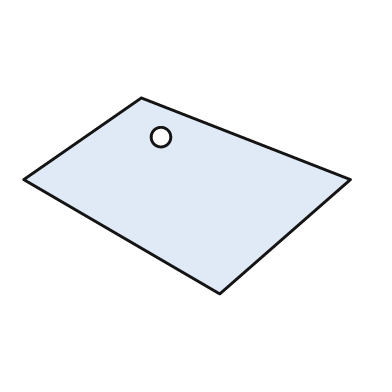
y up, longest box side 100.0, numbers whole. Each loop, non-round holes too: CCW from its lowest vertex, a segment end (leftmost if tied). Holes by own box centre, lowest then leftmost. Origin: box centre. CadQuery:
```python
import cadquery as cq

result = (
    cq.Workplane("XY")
    .moveTo(10.0, -30.0)
    .lineTo(50.0, 5.0)
    .lineTo(-14.0, 30.0)
    .lineTo(-50.0, 5.0)
    .close()
    .moveTo(-8.0, 18.0)
    .circle(3.0)
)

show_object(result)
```